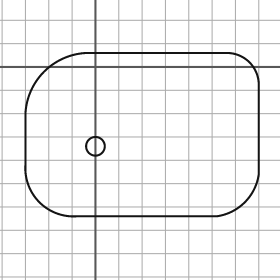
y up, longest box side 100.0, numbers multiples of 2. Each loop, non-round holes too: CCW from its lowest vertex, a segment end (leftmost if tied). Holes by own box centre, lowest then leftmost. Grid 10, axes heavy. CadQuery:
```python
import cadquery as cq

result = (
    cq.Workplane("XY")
    .moveTo(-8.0, -64.0)
    .lineTo(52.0, -64.0)
    .threePointArc((64.0, -58.0), (70.0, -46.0))
    .lineTo(70.0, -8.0)
    .threePointArc((66.0, 2.0), (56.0, 6.0))
    .lineTo(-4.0, 6.0)
    .threePointArc((-22.0, -2.0), (-30.0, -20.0))
    .lineTo(-30.0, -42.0)
    .threePointArc((-24.0, -58.0), (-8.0, -64.0))
    .close()
    .moveTo(0.0, -34.0)
    .circle(4.0)
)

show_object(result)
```